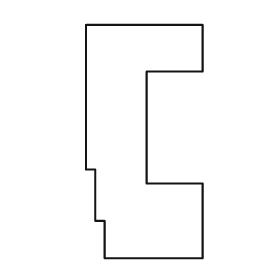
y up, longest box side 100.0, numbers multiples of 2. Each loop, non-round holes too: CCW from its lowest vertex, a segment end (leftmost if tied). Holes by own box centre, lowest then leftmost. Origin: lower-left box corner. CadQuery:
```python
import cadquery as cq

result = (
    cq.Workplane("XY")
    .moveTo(8.0, 0.0)
    .lineTo(50.0, 0.0)
    .lineTo(50.0, 32.0)
    .lineTo(26.0, 32.0)
    .lineTo(26.0, 80.0)
    .lineTo(50.0, 80.0)
    .lineTo(50.0, 100.0)
    .lineTo(0.0, 100.0)
    .lineTo(0.0, 38.0)
    .lineTo(4.0, 38.0)
    .lineTo(4.0, 16.0)
    .lineTo(8.0, 16.0)
    .close()
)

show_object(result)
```